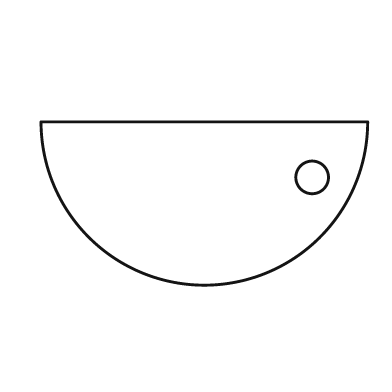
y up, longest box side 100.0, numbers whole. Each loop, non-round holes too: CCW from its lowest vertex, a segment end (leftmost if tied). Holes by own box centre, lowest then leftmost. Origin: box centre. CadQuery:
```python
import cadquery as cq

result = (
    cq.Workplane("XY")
    .moveTo(-50.0, 25.0)
    .threePointArc((0.0, -25.0), (50.0, 25.0))
    .close()
    .moveTo(33.0, 8.0)
    .circle(5.0)
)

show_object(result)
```